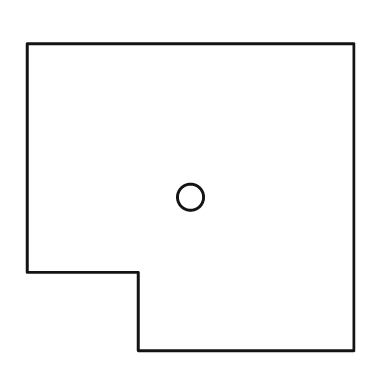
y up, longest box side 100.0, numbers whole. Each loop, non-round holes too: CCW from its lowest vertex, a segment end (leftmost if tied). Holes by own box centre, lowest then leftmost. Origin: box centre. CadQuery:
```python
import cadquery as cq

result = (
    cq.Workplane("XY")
    .moveTo(-16.0, -47.0)
    .lineTo(50.0, -47.0)
    .lineTo(50.0, 47.0)
    .lineTo(-50.0, 47.0)
    .lineTo(-50.0, -23.0)
    .lineTo(-16.0, -23.0)
    .close()
    .moveTo(0.0, 0.0)
    .circle(4.0)
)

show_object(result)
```